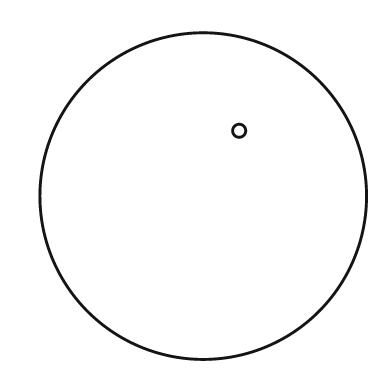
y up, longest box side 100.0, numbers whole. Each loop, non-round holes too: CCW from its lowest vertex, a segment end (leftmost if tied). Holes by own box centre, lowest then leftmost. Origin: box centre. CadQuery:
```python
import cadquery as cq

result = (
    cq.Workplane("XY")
    .moveTo(0.0, 0.0)
    .circle(50.0)
    .moveTo(11.0, 20.0)
    .circle(2.0)
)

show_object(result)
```